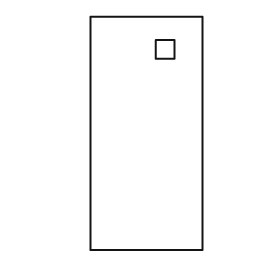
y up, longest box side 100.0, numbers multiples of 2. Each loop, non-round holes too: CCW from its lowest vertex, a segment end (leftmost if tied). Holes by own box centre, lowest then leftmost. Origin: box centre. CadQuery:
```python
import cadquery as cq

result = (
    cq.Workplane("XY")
    .moveTo(-24.0, -50.0)
    .lineTo(24.0, -50.0)
    .lineTo(24.0, 50.0)
    .lineTo(-24.0, 50.0)
    .close()
    .moveTo(4.0, 32.0)
    .lineTo(12.0, 32.0)
    .lineTo(12.0, 40.0)
    .lineTo(4.0, 40.0)
    .close()
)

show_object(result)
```